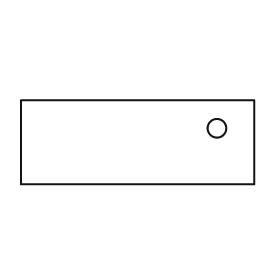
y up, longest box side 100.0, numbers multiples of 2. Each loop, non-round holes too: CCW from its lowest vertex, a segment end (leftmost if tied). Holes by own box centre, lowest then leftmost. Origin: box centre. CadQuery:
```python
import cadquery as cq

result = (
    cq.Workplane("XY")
    .moveTo(-50.0, -18.0)
    .lineTo(50.0, -18.0)
    .lineTo(50.0, 18.0)
    .lineTo(-50.0, 18.0)
    .close()
    .moveTo(34.0, 6.0)
    .circle(4.0)
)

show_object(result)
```